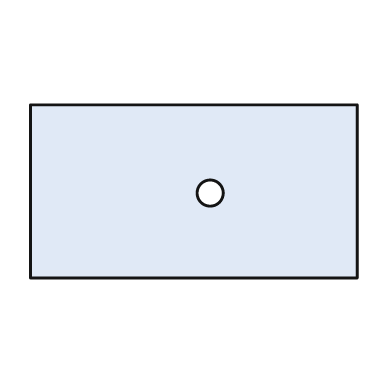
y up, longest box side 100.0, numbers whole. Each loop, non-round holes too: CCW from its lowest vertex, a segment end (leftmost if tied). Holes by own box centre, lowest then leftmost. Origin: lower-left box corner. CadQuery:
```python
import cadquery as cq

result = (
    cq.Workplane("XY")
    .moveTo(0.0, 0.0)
    .lineTo(100.0, 0.0)
    .lineTo(100.0, 53.0)
    .lineTo(0.0, 53.0)
    .close()
    .moveTo(55.0, 26.0)
    .circle(4.0)
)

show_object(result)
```